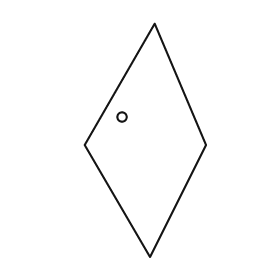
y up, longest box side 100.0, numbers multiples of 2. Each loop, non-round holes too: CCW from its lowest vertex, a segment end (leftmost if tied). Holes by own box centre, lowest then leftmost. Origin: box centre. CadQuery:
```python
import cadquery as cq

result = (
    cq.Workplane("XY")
    .moveTo(2.0, -50.0)
    .lineTo(26.0, -2.0)
    .lineTo(4.0, 50.0)
    .lineTo(-26.0, -2.0)
    .close()
    .moveTo(-10.0, 10.0)
    .circle(2.0)
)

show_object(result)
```